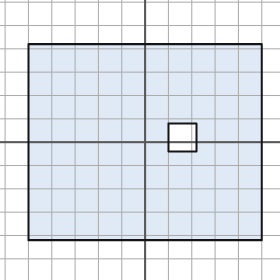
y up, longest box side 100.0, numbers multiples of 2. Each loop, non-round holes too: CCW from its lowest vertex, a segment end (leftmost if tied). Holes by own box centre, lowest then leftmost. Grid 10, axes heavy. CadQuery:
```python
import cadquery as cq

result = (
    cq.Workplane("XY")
    .moveTo(-50.0, -42.0)
    .lineTo(50.0, -42.0)
    .lineTo(50.0, 42.0)
    .lineTo(-50.0, 42.0)
    .close()
    .moveTo(10.0, -4.0)
    .lineTo(22.0, -4.0)
    .lineTo(22.0, 8.0)
    .lineTo(10.0, 8.0)
    .close()
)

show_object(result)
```